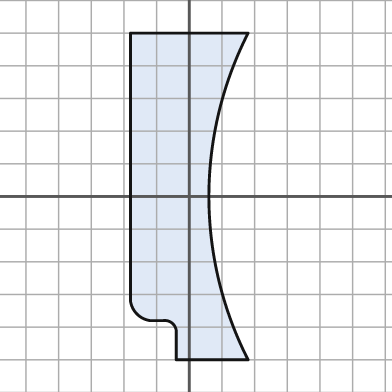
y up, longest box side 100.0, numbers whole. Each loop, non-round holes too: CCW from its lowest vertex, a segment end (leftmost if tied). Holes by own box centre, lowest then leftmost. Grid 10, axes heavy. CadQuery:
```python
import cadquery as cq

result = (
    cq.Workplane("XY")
    .moveTo(-4.0, -50.0)
    .lineTo(18.0, -50.0)
    .threePointArc((6.0, 0.0), (18.0, 50.0))
    .lineTo(-18.0, 50.0)
    .lineTo(-18.0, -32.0)
    .threePointArc((-16.0, -36.0), (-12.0, -38.0))
    .lineTo(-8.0, -38.0)
    .threePointArc((-5.0, -39.0), (-4.0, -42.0))
    .close()
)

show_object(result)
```